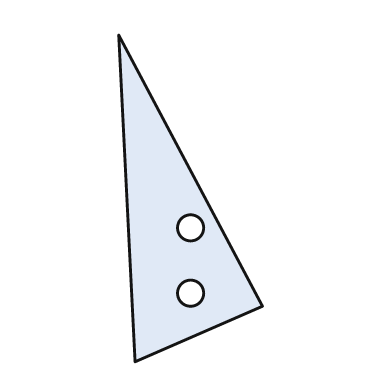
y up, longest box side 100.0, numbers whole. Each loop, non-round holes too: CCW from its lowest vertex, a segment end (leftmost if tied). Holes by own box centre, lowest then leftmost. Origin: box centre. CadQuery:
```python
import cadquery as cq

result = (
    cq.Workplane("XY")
    .moveTo(-17.0, -50.0)
    .lineTo(22.0, -33.0)
    .lineTo(-22.0, 50.0)
    .close()
    .moveTo(0.0, -29.0)
    .circle(4.0)
    .moveTo(0.0, -9.0)
    .circle(4.0)
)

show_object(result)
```